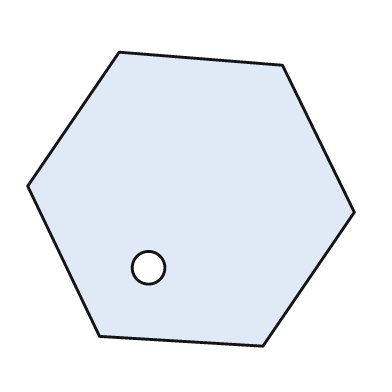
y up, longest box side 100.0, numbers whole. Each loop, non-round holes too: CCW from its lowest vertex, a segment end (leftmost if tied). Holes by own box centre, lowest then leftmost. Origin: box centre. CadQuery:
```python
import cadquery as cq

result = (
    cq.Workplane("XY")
    .moveTo(22.0, -45.0)
    .lineTo(50.0, -4.0)
    .lineTo(28.0, 41.0)
    .lineTo(-22.0, 45.0)
    .lineTo(-50.0, 4.0)
    .lineTo(-28.0, -42.0)
    .close()
    .moveTo(-13.0, -21.0)
    .circle(5.0)
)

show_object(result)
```